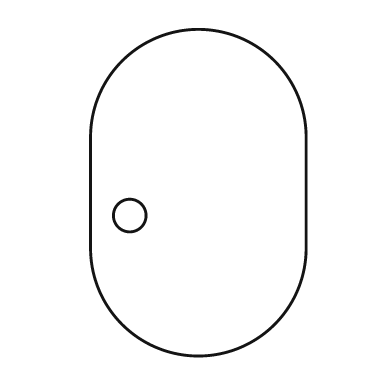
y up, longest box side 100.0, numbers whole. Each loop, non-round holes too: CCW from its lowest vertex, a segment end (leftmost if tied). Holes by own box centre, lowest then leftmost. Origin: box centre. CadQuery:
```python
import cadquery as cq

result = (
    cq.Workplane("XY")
    .moveTo(-33.0, -17.0)
    .threePointArc((0.0, -50.0), (33.0, -17.0))
    .lineTo(33.0, 17.0)
    .threePointArc((0.0, 50.0), (-33.0, 17.0))
    .close()
    .moveTo(-21.0, -7.0)
    .circle(5.0)
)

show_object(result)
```